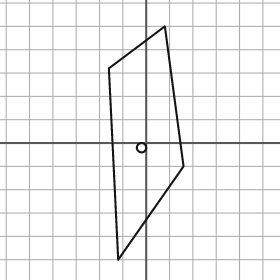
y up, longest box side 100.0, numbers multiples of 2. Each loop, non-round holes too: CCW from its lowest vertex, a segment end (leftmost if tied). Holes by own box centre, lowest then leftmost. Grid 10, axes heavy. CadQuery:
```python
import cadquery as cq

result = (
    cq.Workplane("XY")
    .moveTo(-12.0, -50.0)
    .lineTo(16.0, -10.0)
    .lineTo(8.0, 50.0)
    .lineTo(-16.0, 32.0)
    .close()
    .moveTo(-2.0, -2.0)
    .circle(2.0)
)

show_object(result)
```